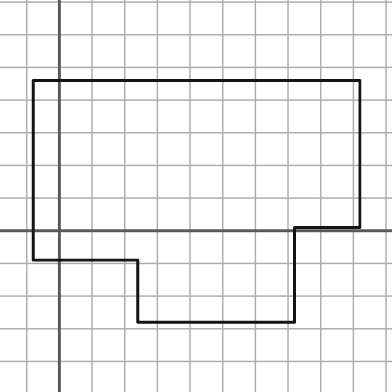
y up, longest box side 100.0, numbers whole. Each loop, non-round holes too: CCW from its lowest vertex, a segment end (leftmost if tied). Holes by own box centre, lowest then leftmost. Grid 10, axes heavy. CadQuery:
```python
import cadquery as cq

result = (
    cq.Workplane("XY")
    .moveTo(24.0, -28.0)
    .lineTo(72.0, -28.0)
    .lineTo(72.0, 1.0)
    .lineTo(92.0, 1.0)
    .lineTo(92.0, 46.0)
    .lineTo(-8.0, 46.0)
    .lineTo(-8.0, -9.0)
    .lineTo(24.0, -9.0)
    .close()
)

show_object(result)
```